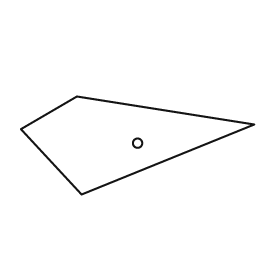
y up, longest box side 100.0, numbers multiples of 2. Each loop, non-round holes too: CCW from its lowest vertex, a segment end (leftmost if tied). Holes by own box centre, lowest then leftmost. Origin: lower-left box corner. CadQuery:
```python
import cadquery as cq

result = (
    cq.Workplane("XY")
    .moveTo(26.0, 0.0)
    .lineTo(100.0, 30.0)
    .lineTo(24.0, 42.0)
    .lineTo(0.0, 28.0)
    .close()
    .moveTo(50.0, 22.0)
    .circle(2.0)
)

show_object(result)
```